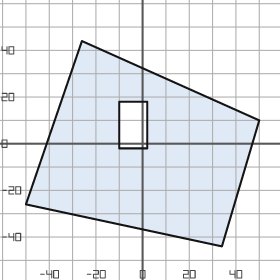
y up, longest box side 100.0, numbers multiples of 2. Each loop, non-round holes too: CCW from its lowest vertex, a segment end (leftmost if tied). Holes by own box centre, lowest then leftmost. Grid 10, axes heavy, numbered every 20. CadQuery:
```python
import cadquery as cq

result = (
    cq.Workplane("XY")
    .moveTo(34.0, -44.0)
    .lineTo(50.0, 10.0)
    .lineTo(-26.0, 44.0)
    .lineTo(-50.0, -26.0)
    .close()
    .moveTo(-10.0, -2.0)
    .lineTo(2.0, -2.0)
    .lineTo(2.0, 18.0)
    .lineTo(-10.0, 18.0)
    .close()
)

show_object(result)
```